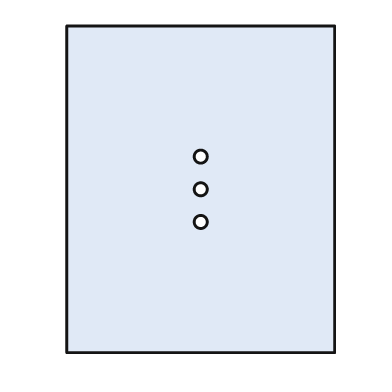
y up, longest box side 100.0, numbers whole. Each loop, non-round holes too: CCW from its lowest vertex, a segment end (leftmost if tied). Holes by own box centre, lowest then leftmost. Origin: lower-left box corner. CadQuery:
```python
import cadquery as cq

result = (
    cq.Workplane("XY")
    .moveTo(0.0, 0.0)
    .lineTo(82.0, 0.0)
    .lineTo(82.0, 100.0)
    .lineTo(0.0, 100.0)
    .close()
    .moveTo(41.0, 40.0)
    .circle(2.0)
    .moveTo(41.0, 50.0)
    .circle(2.0)
    .moveTo(41.0, 60.0)
    .circle(2.0)
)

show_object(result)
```